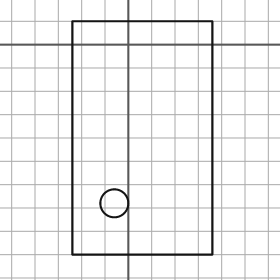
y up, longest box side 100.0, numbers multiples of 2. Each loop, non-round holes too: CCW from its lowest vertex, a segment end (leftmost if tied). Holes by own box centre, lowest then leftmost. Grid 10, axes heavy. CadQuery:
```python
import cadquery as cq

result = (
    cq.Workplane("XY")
    .moveTo(-24.0, -90.0)
    .lineTo(36.0, -90.0)
    .lineTo(36.0, 10.0)
    .lineTo(-24.0, 10.0)
    .close()
    .moveTo(-6.0, -68.0)
    .circle(6.0)
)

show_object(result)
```